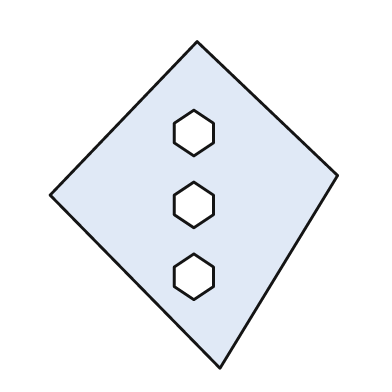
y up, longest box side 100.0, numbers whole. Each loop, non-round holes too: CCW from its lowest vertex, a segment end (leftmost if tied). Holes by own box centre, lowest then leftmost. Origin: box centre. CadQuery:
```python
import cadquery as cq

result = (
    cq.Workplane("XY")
    .moveTo(8.0, -50.0)
    .lineTo(44.0, 9.0)
    .lineTo(1.0, 50.0)
    .lineTo(-44.0, 3.0)
    .close()
    .moveTo(0.0, -29.0)
    .lineTo(6.0, -25.0)
    .lineTo(6.0, -19.0)
    .lineTo(0.0, -15.0)
    .lineTo(-6.0, -19.0)
    .lineTo(-6.0, -25.0)
    .close()
    .moveTo(0.0, -7.0)
    .lineTo(6.0, -3.0)
    .lineTo(6.0, 3.0)
    .lineTo(0.0, 7.0)
    .lineTo(-6.0, 3.0)
    .lineTo(-6.0, -3.0)
    .close()
    .moveTo(0.0, 15.0)
    .lineTo(6.0, 19.0)
    .lineTo(6.0, 25.0)
    .lineTo(0.0, 29.0)
    .lineTo(-6.0, 25.0)
    .lineTo(-6.0, 19.0)
    .close()
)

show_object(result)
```